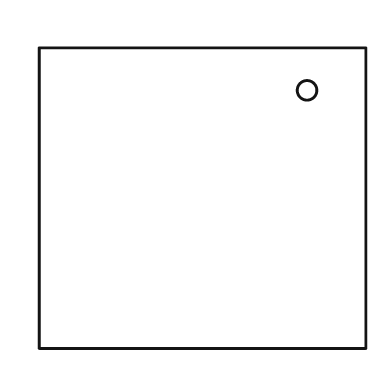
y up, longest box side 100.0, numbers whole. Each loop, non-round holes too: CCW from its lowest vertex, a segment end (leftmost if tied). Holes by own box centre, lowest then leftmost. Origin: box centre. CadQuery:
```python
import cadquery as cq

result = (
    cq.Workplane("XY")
    .moveTo(-50.0, -46.0)
    .lineTo(50.0, -46.0)
    .lineTo(50.0, 46.0)
    .lineTo(-50.0, 46.0)
    .close()
    .moveTo(32.0, 33.0)
    .circle(3.0)
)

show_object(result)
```